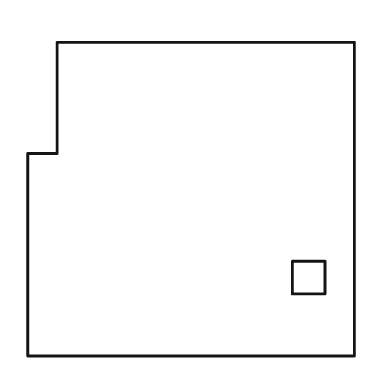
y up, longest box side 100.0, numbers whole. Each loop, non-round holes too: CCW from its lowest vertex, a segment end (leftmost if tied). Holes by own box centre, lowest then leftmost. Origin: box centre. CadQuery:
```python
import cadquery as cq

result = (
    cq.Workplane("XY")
    .moveTo(-50.0, -48.0)
    .lineTo(50.0, -48.0)
    .lineTo(50.0, 48.0)
    .lineTo(-41.0, 48.0)
    .lineTo(-41.0, 14.0)
    .lineTo(-50.0, 14.0)
    .close()
    .moveTo(31.0, -29.0)
    .lineTo(41.0, -29.0)
    .lineTo(41.0, -19.0)
    .lineTo(31.0, -19.0)
    .close()
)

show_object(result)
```